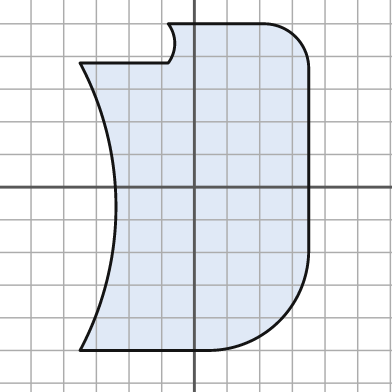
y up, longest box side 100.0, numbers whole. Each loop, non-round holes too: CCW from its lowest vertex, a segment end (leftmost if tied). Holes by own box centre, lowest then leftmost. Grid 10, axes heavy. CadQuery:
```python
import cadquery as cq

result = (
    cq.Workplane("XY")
    .moveTo(-35.0, -50.0)
    .lineTo(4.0, -50.0)
    .threePointArc((26.0, -41.0), (35.0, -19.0))
    .lineTo(35.0, 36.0)
    .threePointArc((31.0, 46.0), (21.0, 50.0))
    .lineTo(-8.0, 50.0)
    .threePointArc((-6.0, 44.0), (-8.0, 38.0))
    .lineTo(-35.0, 38.0)
    .threePointArc((-24.0, -6.0), (-35.0, -50.0))
    .close()
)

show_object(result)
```